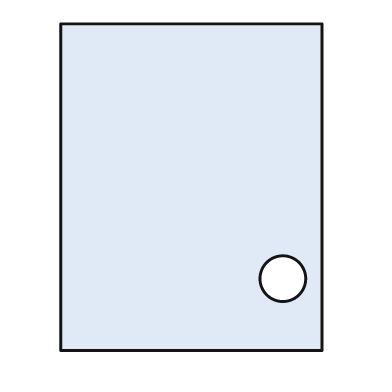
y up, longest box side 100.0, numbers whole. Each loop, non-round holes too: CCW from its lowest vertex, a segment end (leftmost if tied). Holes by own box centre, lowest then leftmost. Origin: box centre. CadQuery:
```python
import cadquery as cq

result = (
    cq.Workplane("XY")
    .moveTo(-40.0, -50.0)
    .lineTo(40.0, -50.0)
    .lineTo(40.0, 50.0)
    .lineTo(-40.0, 50.0)
    .close()
    .moveTo(28.0, -28.0)
    .circle(7.0)
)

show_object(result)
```